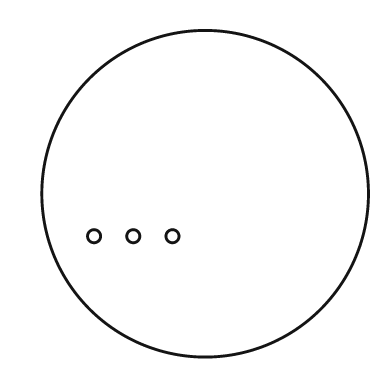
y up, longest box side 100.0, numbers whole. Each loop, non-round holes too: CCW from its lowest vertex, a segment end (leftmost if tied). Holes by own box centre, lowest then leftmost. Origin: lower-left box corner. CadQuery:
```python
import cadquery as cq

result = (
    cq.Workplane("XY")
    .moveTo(50.0, 50.0)
    .circle(50.0)
    .moveTo(16.0, 37.0)
    .circle(2.0)
    .moveTo(28.0, 37.0)
    .circle(2.0)
    .moveTo(40.0, 37.0)
    .circle(2.0)
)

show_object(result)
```